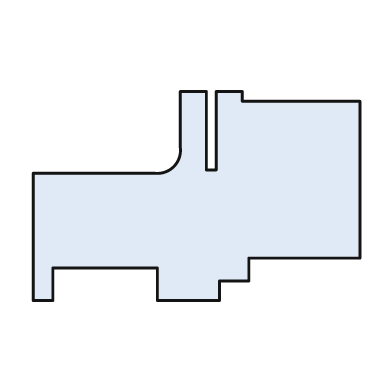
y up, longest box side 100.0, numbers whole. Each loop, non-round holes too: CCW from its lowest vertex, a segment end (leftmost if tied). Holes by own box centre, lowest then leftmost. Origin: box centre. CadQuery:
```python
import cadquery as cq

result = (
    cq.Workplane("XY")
    .moveTo(-50.0, -32.0)
    .lineTo(-44.0, -32.0)
    .lineTo(-44.0, -22.0)
    .lineTo(-12.0, -22.0)
    .lineTo(-12.0, -32.0)
    .lineTo(7.0, -32.0)
    .lineTo(7.0, -26.0)
    .lineTo(16.0, -26.0)
    .lineTo(16.0, -19.0)
    .lineTo(50.0, -19.0)
    .lineTo(50.0, 29.0)
    .lineTo(14.0, 29.0)
    .lineTo(14.0, 32.0)
    .lineTo(6.0, 32.0)
    .lineTo(6.0, 8.0)
    .lineTo(3.0, 8.0)
    .lineTo(3.0, 32.0)
    .lineTo(-5.0, 32.0)
    .lineTo(-5.0, 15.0)
    .threePointArc((-7.0, 9.0), (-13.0, 7.0))
    .lineTo(-50.0, 7.0)
    .close()
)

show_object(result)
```